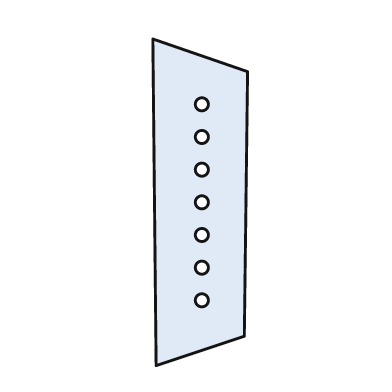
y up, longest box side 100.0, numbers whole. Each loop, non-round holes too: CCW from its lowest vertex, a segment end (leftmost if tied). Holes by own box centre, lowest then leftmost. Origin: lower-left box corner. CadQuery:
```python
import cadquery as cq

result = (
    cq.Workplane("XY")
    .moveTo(1.0, 0.0)
    .lineTo(28.0, 9.0)
    .lineTo(29.0, 90.0)
    .lineTo(0.0, 100.0)
    .close()
    .moveTo(15.0, 20.0)
    .circle(2.0)
    .moveTo(15.0, 30.0)
    .circle(2.0)
    .moveTo(15.0, 40.0)
    .circle(2.0)
    .moveTo(15.0, 50.0)
    .circle(2.0)
    .moveTo(15.0, 60.0)
    .circle(2.0)
    .moveTo(15.0, 70.0)
    .circle(2.0)
    .moveTo(15.0, 80.0)
    .circle(2.0)
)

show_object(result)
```